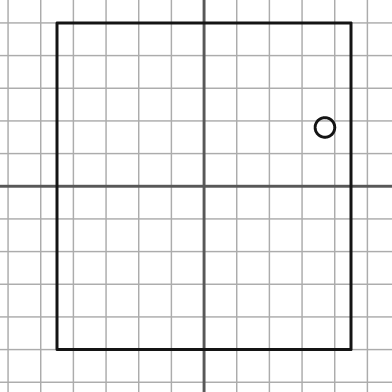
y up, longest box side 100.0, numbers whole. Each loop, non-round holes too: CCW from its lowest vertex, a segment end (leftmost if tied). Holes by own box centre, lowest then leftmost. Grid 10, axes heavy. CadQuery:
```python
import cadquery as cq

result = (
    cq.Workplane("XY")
    .moveTo(-45.0, -50.0)
    .lineTo(45.0, -50.0)
    .lineTo(45.0, 50.0)
    .lineTo(-45.0, 50.0)
    .close()
    .moveTo(37.0, 18.0)
    .circle(3.0)
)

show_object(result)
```